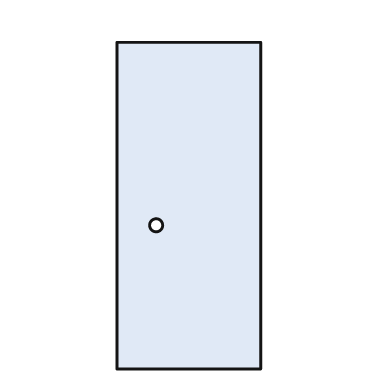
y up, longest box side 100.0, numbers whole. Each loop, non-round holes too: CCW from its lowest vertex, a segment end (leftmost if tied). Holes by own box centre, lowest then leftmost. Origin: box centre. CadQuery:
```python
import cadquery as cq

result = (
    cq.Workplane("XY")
    .moveTo(-22.0, -50.0)
    .lineTo(22.0, -50.0)
    .lineTo(22.0, 50.0)
    .lineTo(-22.0, 50.0)
    .close()
    .moveTo(-10.0, -6.0)
    .circle(2.0)
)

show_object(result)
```